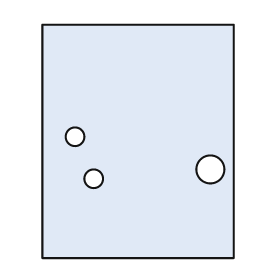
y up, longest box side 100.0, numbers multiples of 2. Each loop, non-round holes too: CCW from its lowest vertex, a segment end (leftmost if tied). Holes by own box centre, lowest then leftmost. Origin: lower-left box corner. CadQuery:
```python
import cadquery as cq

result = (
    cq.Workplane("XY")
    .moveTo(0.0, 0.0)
    .lineTo(82.0, 0.0)
    .lineTo(82.0, 100.0)
    .lineTo(0.0, 100.0)
    .close()
    .moveTo(22.0, 34.0)
    .circle(4.0)
    .moveTo(72.0, 38.0)
    .circle(6.0)
    .moveTo(14.0, 52.0)
    .circle(4.0)
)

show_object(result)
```